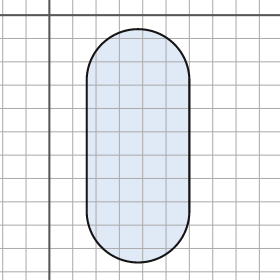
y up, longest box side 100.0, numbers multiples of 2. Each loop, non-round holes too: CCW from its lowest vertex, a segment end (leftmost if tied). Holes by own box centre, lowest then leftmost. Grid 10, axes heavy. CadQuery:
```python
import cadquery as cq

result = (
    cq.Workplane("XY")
    .moveTo(16.0, -84.0)
    .threePointArc((38.0, -106.0), (60.0, -84.0))
    .lineTo(60.0, -28.0)
    .threePointArc((38.0, -6.0), (16.0, -28.0))
    .close()
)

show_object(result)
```